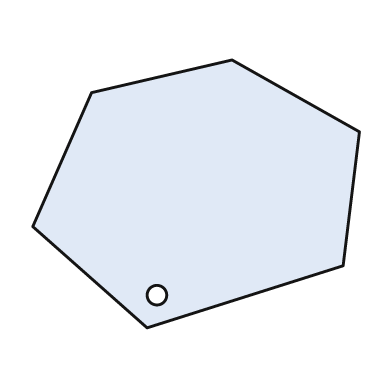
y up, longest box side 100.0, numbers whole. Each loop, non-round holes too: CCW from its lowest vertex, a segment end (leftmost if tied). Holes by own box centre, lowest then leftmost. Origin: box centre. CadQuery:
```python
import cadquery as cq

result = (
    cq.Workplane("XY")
    .moveTo(-15.0, -41.0)
    .lineTo(45.0, -22.0)
    .lineTo(50.0, 19.0)
    .lineTo(11.0, 41.0)
    .lineTo(-32.0, 31.0)
    .lineTo(-50.0, -10.0)
    .close()
    .moveTo(-12.0, -31.0)
    .circle(3.0)
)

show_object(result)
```